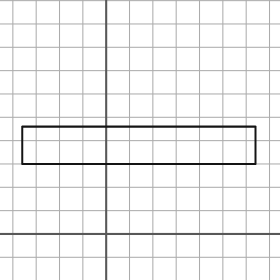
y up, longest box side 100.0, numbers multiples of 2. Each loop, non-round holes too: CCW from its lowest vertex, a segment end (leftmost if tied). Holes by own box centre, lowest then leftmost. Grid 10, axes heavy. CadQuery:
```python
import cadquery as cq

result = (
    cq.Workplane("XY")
    .moveTo(-36.0, 30.0)
    .lineTo(64.0, 30.0)
    .lineTo(64.0, 46.0)
    .lineTo(-36.0, 46.0)
    .close()
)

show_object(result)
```